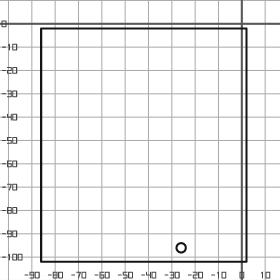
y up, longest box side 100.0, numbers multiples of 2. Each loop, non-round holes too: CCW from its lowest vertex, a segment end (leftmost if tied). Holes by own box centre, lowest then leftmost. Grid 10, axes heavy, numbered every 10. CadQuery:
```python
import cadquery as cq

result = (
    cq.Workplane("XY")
    .moveTo(-86.0, -102.0)
    .lineTo(2.0, -102.0)
    .lineTo(2.0, -2.0)
    .lineTo(-86.0, -2.0)
    .close()
    .moveTo(-26.0, -96.0)
    .circle(2.0)
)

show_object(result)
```